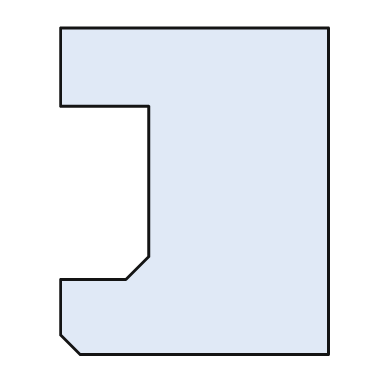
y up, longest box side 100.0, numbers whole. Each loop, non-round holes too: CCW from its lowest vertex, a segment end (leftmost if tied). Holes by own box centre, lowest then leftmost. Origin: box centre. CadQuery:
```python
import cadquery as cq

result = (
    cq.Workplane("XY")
    .moveTo(-35.0, -50.0)
    .lineTo(41.0, -50.0)
    .lineTo(41.0, 50.0)
    .lineTo(-41.0, 50.0)
    .lineTo(-41.0, 26.0)
    .lineTo(-14.0, 26.0)
    .lineTo(-14.0, -20.0)
    .lineTo(-21.0, -27.0)
    .lineTo(-41.0, -27.0)
    .lineTo(-41.0, -44.0)
    .close()
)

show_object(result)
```